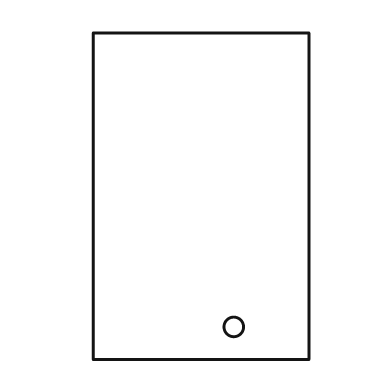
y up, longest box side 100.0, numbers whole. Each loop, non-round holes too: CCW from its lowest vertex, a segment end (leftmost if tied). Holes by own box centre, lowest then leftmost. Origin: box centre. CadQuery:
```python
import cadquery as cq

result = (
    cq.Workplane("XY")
    .moveTo(-33.0, -50.0)
    .lineTo(33.0, -50.0)
    .lineTo(33.0, 50.0)
    .lineTo(-33.0, 50.0)
    .close()
    .moveTo(10.0, -40.0)
    .circle(3.0)
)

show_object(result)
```